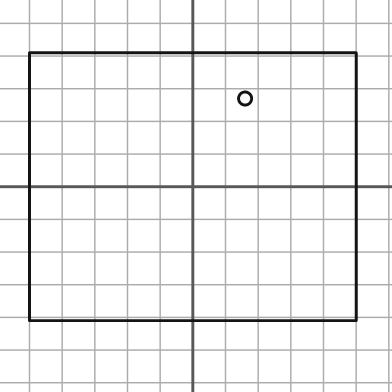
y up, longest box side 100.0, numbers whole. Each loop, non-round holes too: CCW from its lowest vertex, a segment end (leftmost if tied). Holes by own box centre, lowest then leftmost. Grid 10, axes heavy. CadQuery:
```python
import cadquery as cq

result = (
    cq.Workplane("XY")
    .moveTo(-50.0, -41.0)
    .lineTo(50.0, -41.0)
    .lineTo(50.0, 41.0)
    .lineTo(-50.0, 41.0)
    .close()
    .moveTo(16.0, 27.0)
    .circle(2.0)
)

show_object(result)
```